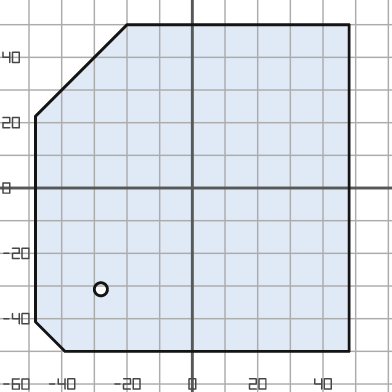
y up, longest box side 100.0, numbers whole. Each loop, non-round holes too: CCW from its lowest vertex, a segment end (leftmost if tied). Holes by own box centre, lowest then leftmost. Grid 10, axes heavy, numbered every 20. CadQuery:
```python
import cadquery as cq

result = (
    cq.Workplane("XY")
    .moveTo(-39.0, -50.0)
    .lineTo(48.0, -50.0)
    .lineTo(48.0, 50.0)
    .lineTo(-20.0, 50.0)
    .lineTo(-48.0, 22.0)
    .lineTo(-48.0, -41.0)
    .close()
    .moveTo(-28.0, -31.0)
    .circle(2.0)
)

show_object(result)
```